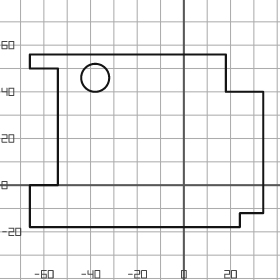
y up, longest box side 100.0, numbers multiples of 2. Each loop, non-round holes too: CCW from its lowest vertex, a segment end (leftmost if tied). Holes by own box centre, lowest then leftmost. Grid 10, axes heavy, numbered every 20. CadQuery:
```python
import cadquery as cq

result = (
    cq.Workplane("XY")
    .moveTo(-66.0, -18.0)
    .lineTo(24.0, -18.0)
    .lineTo(24.0, -12.0)
    .lineTo(34.0, -12.0)
    .lineTo(34.0, 40.0)
    .lineTo(18.0, 40.0)
    .lineTo(18.0, 56.0)
    .lineTo(-66.0, 56.0)
    .lineTo(-66.0, 50.0)
    .lineTo(-54.0, 50.0)
    .lineTo(-54.0, 0.0)
    .lineTo(-66.0, 0.0)
    .close()
    .moveTo(-38.0, 46.0)
    .circle(6.0)
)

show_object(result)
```